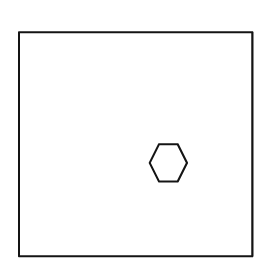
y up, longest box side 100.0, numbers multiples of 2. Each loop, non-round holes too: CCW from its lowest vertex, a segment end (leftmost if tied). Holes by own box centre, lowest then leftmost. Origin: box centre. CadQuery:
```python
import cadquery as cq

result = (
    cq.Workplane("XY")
    .moveTo(-50.0, -48.0)
    .lineTo(50.0, -48.0)
    .lineTo(50.0, 48.0)
    .lineTo(-50.0, 48.0)
    .close()
    .moveTo(10.0, -16.0)
    .lineTo(18.0, -16.0)
    .lineTo(22.0, -8.0)
    .lineTo(18.0, 0.0)
    .lineTo(10.0, 0.0)
    .lineTo(6.0, -8.0)
    .close()
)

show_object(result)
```